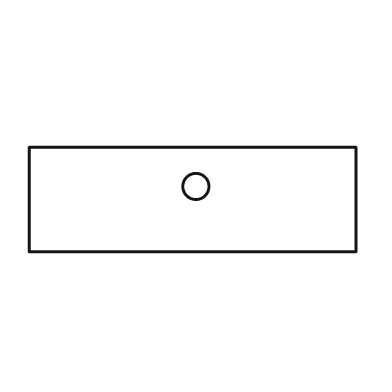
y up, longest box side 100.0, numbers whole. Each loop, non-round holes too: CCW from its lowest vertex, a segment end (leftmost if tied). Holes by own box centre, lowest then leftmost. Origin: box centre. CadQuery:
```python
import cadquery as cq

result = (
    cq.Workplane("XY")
    .moveTo(-50.0, -16.0)
    .lineTo(50.0, -16.0)
    .lineTo(50.0, 16.0)
    .lineTo(-50.0, 16.0)
    .close()
    .moveTo(1.0, 4.0)
    .circle(4.0)
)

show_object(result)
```